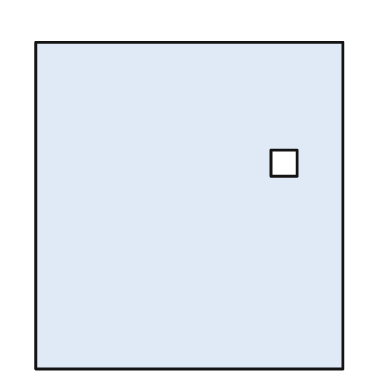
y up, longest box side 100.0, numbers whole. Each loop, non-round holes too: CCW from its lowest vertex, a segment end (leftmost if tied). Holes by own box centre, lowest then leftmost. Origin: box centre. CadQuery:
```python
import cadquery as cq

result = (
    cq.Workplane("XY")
    .moveTo(-47.0, -50.0)
    .lineTo(47.0, -50.0)
    .lineTo(47.0, 50.0)
    .lineTo(-47.0, 50.0)
    .close()
    .moveTo(25.0, 9.0)
    .lineTo(33.0, 9.0)
    .lineTo(33.0, 17.0)
    .lineTo(25.0, 17.0)
    .close()
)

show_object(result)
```